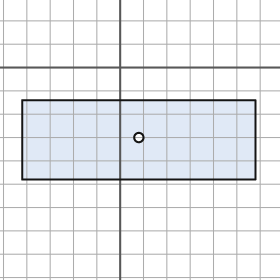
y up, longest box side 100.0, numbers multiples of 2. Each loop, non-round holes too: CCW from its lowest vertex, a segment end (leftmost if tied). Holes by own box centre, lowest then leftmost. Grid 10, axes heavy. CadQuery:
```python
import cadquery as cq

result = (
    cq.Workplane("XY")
    .moveTo(-42.0, -48.0)
    .lineTo(58.0, -48.0)
    .lineTo(58.0, -14.0)
    .lineTo(-42.0, -14.0)
    .close()
    .moveTo(8.0, -30.0)
    .circle(2.0)
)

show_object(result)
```